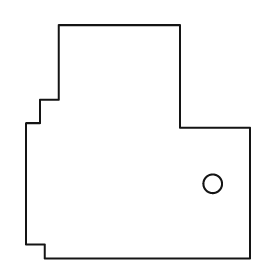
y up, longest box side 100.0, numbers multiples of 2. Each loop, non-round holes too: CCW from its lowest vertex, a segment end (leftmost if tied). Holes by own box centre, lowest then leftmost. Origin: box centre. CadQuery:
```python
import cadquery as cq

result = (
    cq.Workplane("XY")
    .moveTo(-40.0, -50.0)
    .lineTo(48.0, -50.0)
    .lineTo(48.0, 6.0)
    .lineTo(18.0, 6.0)
    .lineTo(18.0, 50.0)
    .lineTo(-34.0, 50.0)
    .lineTo(-34.0, 18.0)
    .lineTo(-42.0, 18.0)
    .lineTo(-42.0, 8.0)
    .lineTo(-48.0, 8.0)
    .lineTo(-48.0, -44.0)
    .lineTo(-40.0, -44.0)
    .close()
    .moveTo(32.0, -18.0)
    .circle(4.0)
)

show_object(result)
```